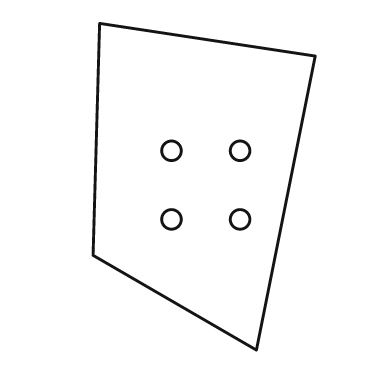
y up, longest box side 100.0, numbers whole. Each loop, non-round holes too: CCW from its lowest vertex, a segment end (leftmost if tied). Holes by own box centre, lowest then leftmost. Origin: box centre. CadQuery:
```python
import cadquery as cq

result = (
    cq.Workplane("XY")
    .moveTo(16.0, -50.0)
    .lineTo(34.0, 40.0)
    .lineTo(-32.0, 50.0)
    .lineTo(-34.0, -21.0)
    .close()
    .moveTo(-10.0, -10.0)
    .circle(3.0)
    .moveTo(11.0, -10.0)
    .circle(3.0)
    .moveTo(-10.0, 11.0)
    .circle(3.0)
    .moveTo(11.0, 11.0)
    .circle(3.0)
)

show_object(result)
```